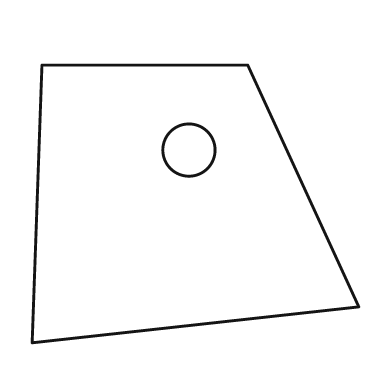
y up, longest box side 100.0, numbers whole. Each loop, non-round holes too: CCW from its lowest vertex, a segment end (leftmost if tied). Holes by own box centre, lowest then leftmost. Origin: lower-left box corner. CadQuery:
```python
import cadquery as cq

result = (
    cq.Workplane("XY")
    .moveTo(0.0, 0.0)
    .lineTo(100.0, 11.0)
    .lineTo(66.0, 85.0)
    .lineTo(3.0, 85.0)
    .close()
    .moveTo(48.0, 59.0)
    .circle(8.0)
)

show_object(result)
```